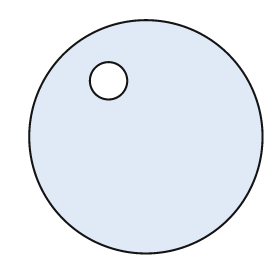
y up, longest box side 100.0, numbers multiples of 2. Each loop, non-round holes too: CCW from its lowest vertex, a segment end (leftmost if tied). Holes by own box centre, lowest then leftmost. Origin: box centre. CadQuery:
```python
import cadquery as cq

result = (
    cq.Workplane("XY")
    .moveTo(0.0, 0.0)
    .circle(50.0)
    .moveTo(-16.0, 24.0)
    .circle(8.0)
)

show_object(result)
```